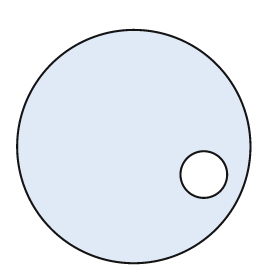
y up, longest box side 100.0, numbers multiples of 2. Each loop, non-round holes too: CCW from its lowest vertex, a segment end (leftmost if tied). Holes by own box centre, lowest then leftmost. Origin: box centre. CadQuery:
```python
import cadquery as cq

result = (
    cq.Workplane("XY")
    .moveTo(0.0, 0.0)
    .circle(50.0)
    .moveTo(30.0, -12.0)
    .circle(10.0)
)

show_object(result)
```